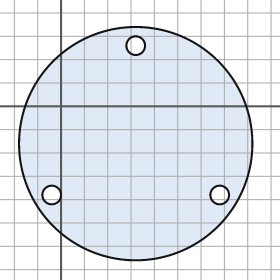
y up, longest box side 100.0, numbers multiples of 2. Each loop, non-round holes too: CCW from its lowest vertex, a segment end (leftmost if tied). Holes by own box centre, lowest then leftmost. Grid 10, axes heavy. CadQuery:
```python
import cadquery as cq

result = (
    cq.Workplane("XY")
    .moveTo(32.0, -16.0)
    .circle(50.0)
    .moveTo(-4.0, -38.0)
    .circle(4.0)
    .moveTo(68.0, -38.0)
    .circle(4.0)
    .moveTo(32.0, 26.0)
    .circle(4.0)
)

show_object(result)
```